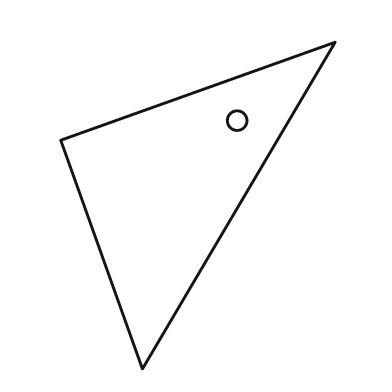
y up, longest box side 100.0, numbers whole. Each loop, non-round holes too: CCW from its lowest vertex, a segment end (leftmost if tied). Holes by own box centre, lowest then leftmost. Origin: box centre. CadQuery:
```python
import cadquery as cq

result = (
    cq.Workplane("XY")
    .moveTo(-17.0, -50.0)
    .lineTo(42.0, 50.0)
    .lineTo(-42.0, 20.0)
    .close()
    .moveTo(12.0, 26.0)
    .circle(3.0)
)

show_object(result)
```